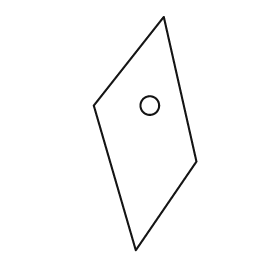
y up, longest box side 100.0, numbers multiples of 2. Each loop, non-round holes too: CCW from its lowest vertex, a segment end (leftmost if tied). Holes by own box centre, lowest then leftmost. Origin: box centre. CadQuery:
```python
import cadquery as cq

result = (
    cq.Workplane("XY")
    .moveTo(-4.0, -50.0)
    .lineTo(22.0, -12.0)
    .lineTo(8.0, 50.0)
    .lineTo(-22.0, 12.0)
    .close()
    .moveTo(2.0, 12.0)
    .circle(4.0)
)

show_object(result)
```